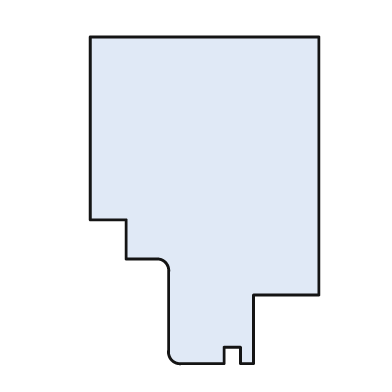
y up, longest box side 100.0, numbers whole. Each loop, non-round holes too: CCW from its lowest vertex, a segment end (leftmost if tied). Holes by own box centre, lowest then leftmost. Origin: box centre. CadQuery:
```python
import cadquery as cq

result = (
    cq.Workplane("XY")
    .moveTo(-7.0, -50.0)
    .lineTo(6.0, -50.0)
    .lineTo(6.0, -45.0)
    .lineTo(11.0, -45.0)
    .lineTo(11.0, -50.0)
    .lineTo(15.0, -50.0)
    .lineTo(15.0, -29.0)
    .lineTo(35.0, -29.0)
    .lineTo(35.0, 50.0)
    .lineTo(-35.0, 50.0)
    .lineTo(-35.0, -6.0)
    .lineTo(-24.0, -6.0)
    .lineTo(-24.0, -18.0)
    .lineTo(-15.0, -18.0)
    .threePointArc((-12.0, -19.0), (-11.0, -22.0))
    .lineTo(-11.0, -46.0)
    .threePointArc((-10.0, -49.0), (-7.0, -50.0))
    .close()
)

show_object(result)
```